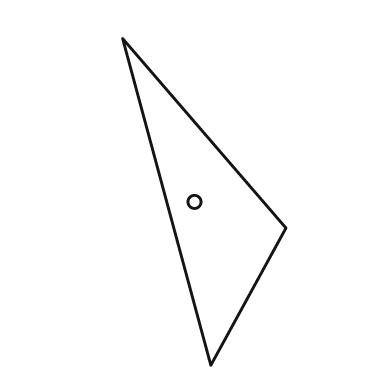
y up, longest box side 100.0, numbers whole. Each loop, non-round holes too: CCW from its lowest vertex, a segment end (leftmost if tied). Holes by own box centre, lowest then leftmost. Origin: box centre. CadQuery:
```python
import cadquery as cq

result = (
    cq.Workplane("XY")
    .moveTo(2.0, -50.0)
    .lineTo(25.0, -8.0)
    .lineTo(-25.0, 50.0)
    .close()
    .moveTo(-3.0, 0.0)
    .circle(2.0)
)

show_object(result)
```